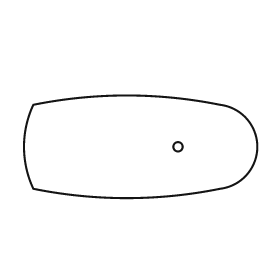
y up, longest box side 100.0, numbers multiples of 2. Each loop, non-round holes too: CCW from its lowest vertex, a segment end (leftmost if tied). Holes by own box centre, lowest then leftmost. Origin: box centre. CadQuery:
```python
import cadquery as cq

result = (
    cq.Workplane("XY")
    .moveTo(-46.0, -18.0)
    .threePointArc((-6.0, -22.0), (34.0, -18.0))
    .threePointArc((50.0, 0.0), (34.0, 18.0))
    .threePointArc((-6.0, 22.0), (-46.0, 18.0))
    .threePointArc((-50.0, 0.0), (-46.0, -18.0))
    .close()
    .moveTo(16.0, 0.0)
    .circle(2.0)
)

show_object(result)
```